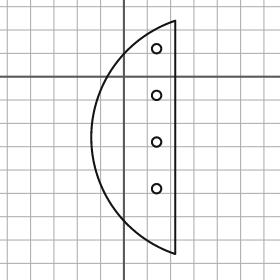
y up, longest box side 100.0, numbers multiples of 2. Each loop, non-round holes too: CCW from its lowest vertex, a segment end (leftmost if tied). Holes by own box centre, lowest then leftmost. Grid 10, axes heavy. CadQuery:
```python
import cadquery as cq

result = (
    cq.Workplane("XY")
    .moveTo(22.0, -76.0)
    .lineTo(22.0, 24.0)
    .threePointArc((-14.0, -26.0), (22.0, -76.0))
    .close()
    .moveTo(14.0, -48.0)
    .circle(2.0)
    .moveTo(14.0, -28.0)
    .circle(2.0)
    .moveTo(14.0, -8.0)
    .circle(2.0)
    .moveTo(14.0, 12.0)
    .circle(2.0)
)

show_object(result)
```